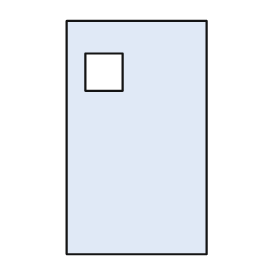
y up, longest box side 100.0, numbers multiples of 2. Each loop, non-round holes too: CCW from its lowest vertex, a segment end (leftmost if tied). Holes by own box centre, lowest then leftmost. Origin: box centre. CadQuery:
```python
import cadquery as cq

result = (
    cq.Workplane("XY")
    .moveTo(-30.0, -50.0)
    .lineTo(30.0, -50.0)
    .lineTo(30.0, 50.0)
    .lineTo(-30.0, 50.0)
    .close()
    .moveTo(-22.0, 20.0)
    .lineTo(-6.0, 20.0)
    .lineTo(-6.0, 36.0)
    .lineTo(-22.0, 36.0)
    .close()
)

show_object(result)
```